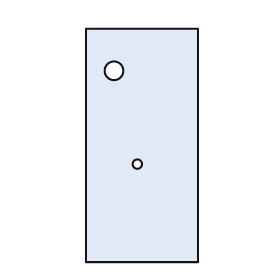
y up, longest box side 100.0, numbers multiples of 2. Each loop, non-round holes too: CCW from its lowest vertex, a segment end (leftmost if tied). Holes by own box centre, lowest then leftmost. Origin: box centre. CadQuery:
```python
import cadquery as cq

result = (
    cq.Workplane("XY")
    .moveTo(-24.0, -50.0)
    .lineTo(24.0, -50.0)
    .lineTo(24.0, 50.0)
    .lineTo(-24.0, 50.0)
    .close()
    .moveTo(-2.0, -8.0)
    .circle(2.0)
    .moveTo(-12.0, 32.0)
    .circle(4.0)
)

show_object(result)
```